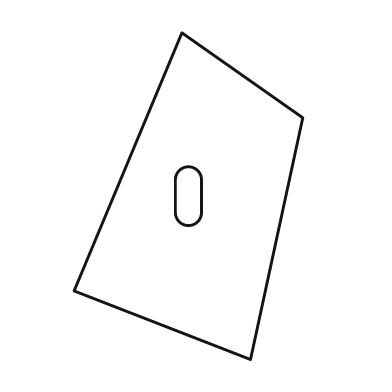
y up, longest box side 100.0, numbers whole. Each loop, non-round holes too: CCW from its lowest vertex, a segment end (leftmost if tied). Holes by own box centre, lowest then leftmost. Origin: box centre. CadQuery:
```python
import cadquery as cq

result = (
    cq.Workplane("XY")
    .moveTo(19.0, -50.0)
    .lineTo(35.0, 24.0)
    .lineTo(-2.0, 50.0)
    .lineTo(-35.0, -29.0)
    .close()
    .moveTo(-4.0, -5.0)
    .threePointArc((0.0, -9.0), (4.0, -5.0))
    .lineTo(4.0, 5.0)
    .threePointArc((0.0, 9.0), (-4.0, 5.0))
    .close()
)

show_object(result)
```